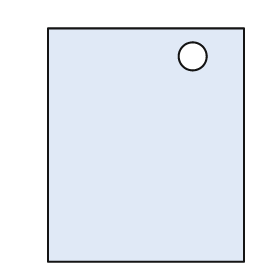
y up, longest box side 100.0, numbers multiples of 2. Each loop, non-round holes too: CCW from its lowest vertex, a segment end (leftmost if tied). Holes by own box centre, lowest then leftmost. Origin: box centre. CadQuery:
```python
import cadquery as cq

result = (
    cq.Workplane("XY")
    .moveTo(-42.0, -50.0)
    .lineTo(42.0, -50.0)
    .lineTo(42.0, 50.0)
    .lineTo(-42.0, 50.0)
    .close()
    .moveTo(20.0, 38.0)
    .circle(6.0)
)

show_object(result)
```